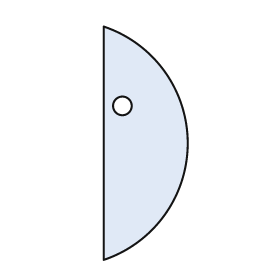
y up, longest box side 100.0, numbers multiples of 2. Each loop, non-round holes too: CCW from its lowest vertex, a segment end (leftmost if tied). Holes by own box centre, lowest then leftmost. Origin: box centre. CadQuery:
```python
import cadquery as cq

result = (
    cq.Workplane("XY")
    .moveTo(-18.0, -50.0)
    .threePointArc((18.0, 0.0), (-18.0, 50.0))
    .close()
    .moveTo(-10.0, 16.0)
    .circle(4.0)
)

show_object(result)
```